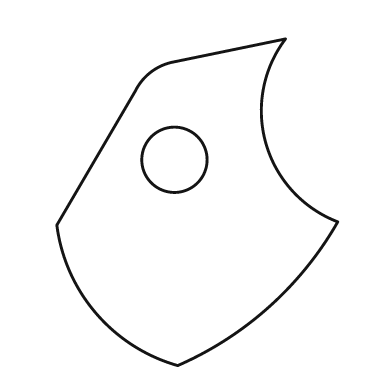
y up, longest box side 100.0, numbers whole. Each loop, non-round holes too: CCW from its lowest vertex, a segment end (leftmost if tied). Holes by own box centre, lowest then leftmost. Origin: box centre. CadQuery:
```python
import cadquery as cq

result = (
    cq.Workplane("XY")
    .moveTo(-6.0, -50.0)
    .threePointArc((22.0, -32.0), (43.0, -6.0))
    .threePointArc((21.0, 18.0), (27.0, 50.0))
    .lineTo(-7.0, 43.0)
    .threePointArc((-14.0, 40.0), (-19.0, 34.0))
    .lineTo(-43.0, -7.0)
    .threePointArc((-31.0, -34.0), (-6.0, -50.0))
    .close()
    .moveTo(-7.0, 13.0)
    .circle(10.0)
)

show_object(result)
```